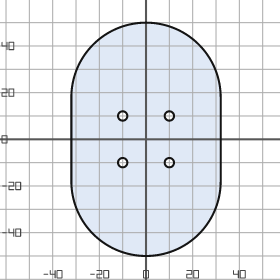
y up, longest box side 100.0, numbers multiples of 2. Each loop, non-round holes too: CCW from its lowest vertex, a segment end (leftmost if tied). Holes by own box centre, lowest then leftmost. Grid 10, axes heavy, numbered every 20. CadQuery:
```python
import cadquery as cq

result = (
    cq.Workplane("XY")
    .moveTo(-32.0, -18.0)
    .threePointArc((0.0, -50.0), (32.0, -18.0))
    .lineTo(32.0, 18.0)
    .threePointArc((0.0, 50.0), (-32.0, 18.0))
    .close()
    .moveTo(-10.0, -10.0)
    .circle(2.0)
    .moveTo(10.0, -10.0)
    .circle(2.0)
    .moveTo(-10.0, 10.0)
    .circle(2.0)
    .moveTo(10.0, 10.0)
    .circle(2.0)
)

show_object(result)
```